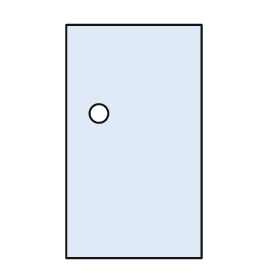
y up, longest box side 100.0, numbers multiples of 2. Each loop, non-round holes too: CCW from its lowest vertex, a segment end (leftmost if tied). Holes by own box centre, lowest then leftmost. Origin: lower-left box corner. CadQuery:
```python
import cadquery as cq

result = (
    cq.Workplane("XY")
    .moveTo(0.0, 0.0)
    .lineTo(58.0, 0.0)
    .lineTo(58.0, 100.0)
    .lineTo(0.0, 100.0)
    .close()
    .moveTo(14.0, 62.0)
    .circle(4.0)
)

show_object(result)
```